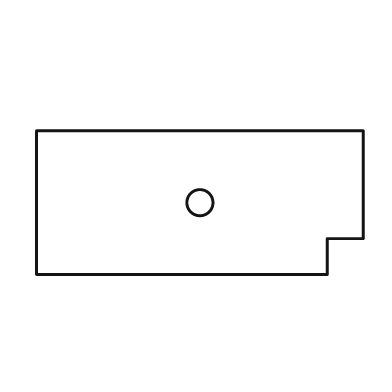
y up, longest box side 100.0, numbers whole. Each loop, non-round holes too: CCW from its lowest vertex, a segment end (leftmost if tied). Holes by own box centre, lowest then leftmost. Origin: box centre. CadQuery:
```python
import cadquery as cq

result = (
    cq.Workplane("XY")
    .moveTo(-50.0, -22.0)
    .lineTo(39.0, -22.0)
    .lineTo(39.0, -11.0)
    .lineTo(50.0, -11.0)
    .lineTo(50.0, 22.0)
    .lineTo(-50.0, 22.0)
    .close()
    .moveTo(0.0, 0.0)
    .circle(4.0)
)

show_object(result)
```